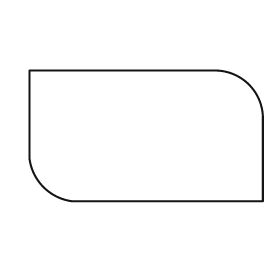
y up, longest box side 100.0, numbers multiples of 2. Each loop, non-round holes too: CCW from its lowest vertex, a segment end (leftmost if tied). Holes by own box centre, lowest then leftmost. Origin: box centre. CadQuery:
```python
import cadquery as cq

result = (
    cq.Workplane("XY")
    .moveTo(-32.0, -28.0)
    .lineTo(50.0, -28.0)
    .lineTo(50.0, 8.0)
    .threePointArc((44.0, 22.0), (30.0, 28.0))
    .lineTo(-50.0, 28.0)
    .lineTo(-50.0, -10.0)
    .threePointArc((-44.0, -22.0), (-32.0, -28.0))
    .close()
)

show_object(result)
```